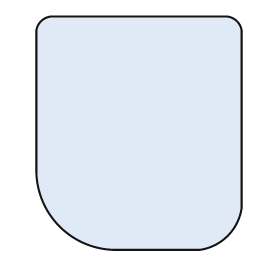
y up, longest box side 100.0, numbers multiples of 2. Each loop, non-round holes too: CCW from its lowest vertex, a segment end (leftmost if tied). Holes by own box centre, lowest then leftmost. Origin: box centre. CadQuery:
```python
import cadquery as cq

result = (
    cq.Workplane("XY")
    .moveTo(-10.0, -50.0)
    .lineTo(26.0, -50.0)
    .threePointArc((38.0, -44.0), (44.0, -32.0))
    .lineTo(44.0, 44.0)
    .threePointArc((42.0, 48.0), (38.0, 50.0))
    .lineTo(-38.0, 50.0)
    .threePointArc((-42.0, 48.0), (-44.0, 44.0))
    .lineTo(-44.0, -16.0)
    .threePointArc((-34.0, -40.0), (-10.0, -50.0))
    .close()
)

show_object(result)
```